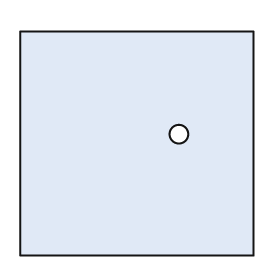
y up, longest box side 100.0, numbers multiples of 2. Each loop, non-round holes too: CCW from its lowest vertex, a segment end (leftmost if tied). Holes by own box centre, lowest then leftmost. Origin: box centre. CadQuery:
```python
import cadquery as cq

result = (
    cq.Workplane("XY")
    .moveTo(-50.0, -48.0)
    .lineTo(50.0, -48.0)
    .lineTo(50.0, 48.0)
    .lineTo(-50.0, 48.0)
    .close()
    .moveTo(18.0, 4.0)
    .circle(4.0)
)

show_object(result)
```